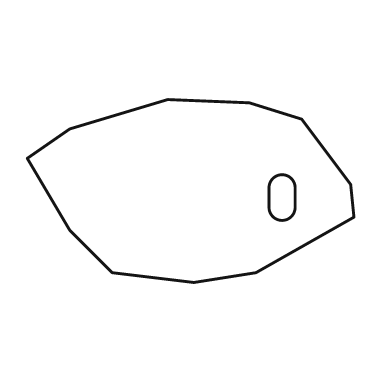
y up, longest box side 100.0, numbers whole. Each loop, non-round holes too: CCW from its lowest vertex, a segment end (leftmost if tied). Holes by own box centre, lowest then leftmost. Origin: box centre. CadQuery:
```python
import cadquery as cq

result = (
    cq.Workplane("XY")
    .moveTo(1.0, -28.0)
    .lineTo(20.0, -25.0)
    .lineTo(50.0, -8.0)
    .lineTo(49.0, 2.0)
    .lineTo(34.0, 22.0)
    .lineTo(18.0, 27.0)
    .lineTo(-7.0, 28.0)
    .lineTo(-37.0, 19.0)
    .lineTo(-50.0, 10.0)
    .lineTo(-37.0, -12.0)
    .lineTo(-24.0, -25.0)
    .close()
    .moveTo(24.0, -5.0)
    .threePointArc((28.0, -9.0), (32.0, -5.0))
    .lineTo(32.0, 1.0)
    .threePointArc((28.0, 5.0), (24.0, 1.0))
    .close()
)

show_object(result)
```